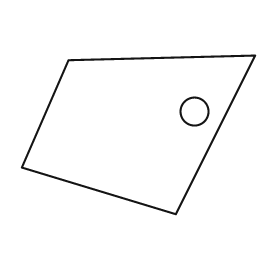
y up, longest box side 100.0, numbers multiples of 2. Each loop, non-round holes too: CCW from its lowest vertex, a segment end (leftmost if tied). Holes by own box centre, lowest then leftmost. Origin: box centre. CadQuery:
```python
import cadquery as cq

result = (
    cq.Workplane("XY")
    .moveTo(16.0, -34.0)
    .lineTo(50.0, 34.0)
    .lineTo(-30.0, 32.0)
    .lineTo(-50.0, -14.0)
    .close()
    .moveTo(24.0, 10.0)
    .circle(6.0)
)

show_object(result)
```